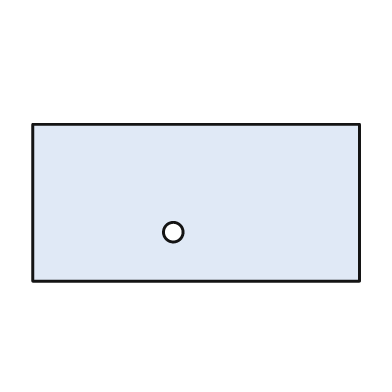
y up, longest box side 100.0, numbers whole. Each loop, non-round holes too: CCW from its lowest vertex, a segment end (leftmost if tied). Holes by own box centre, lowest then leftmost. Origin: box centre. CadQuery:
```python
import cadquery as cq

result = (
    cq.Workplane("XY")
    .moveTo(-50.0, -24.0)
    .lineTo(50.0, -24.0)
    .lineTo(50.0, 24.0)
    .lineTo(-50.0, 24.0)
    .close()
    .moveTo(-7.0, -9.0)
    .circle(3.0)
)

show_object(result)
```